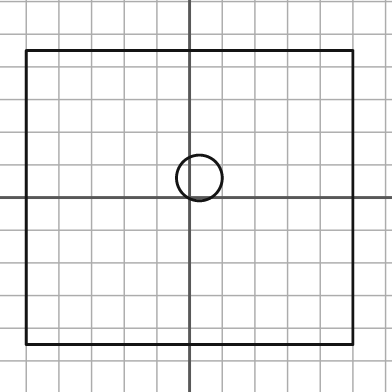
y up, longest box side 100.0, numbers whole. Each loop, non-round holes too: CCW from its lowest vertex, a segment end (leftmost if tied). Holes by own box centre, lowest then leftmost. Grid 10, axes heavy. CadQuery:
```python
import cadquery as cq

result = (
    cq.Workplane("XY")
    .moveTo(-50.0, -45.0)
    .lineTo(50.0, -45.0)
    .lineTo(50.0, 45.0)
    .lineTo(-50.0, 45.0)
    .close()
    .moveTo(3.0, 6.0)
    .circle(7.0)
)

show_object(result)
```